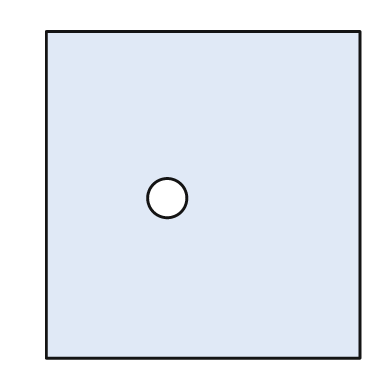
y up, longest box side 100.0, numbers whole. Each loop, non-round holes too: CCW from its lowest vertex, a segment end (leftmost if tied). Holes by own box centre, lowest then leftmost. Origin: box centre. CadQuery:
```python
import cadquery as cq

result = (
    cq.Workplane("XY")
    .moveTo(-48.0, -50.0)
    .lineTo(48.0, -50.0)
    .lineTo(48.0, 50.0)
    .lineTo(-48.0, 50.0)
    .close()
    .moveTo(-11.0, -1.0)
    .circle(6.0)
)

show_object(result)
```